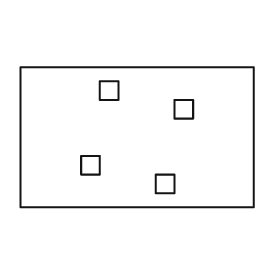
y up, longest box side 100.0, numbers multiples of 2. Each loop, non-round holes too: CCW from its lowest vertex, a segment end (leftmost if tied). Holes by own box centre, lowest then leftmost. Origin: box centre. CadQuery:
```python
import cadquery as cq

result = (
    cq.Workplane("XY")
    .moveTo(-50.0, -30.0)
    .lineTo(50.0, -30.0)
    .lineTo(50.0, 30.0)
    .lineTo(-50.0, 30.0)
    .close()
    .moveTo(8.0, -24.0)
    .lineTo(16.0, -24.0)
    .lineTo(16.0, -16.0)
    .lineTo(8.0, -16.0)
    .close()
    .moveTo(-24.0, -16.0)
    .lineTo(-16.0, -16.0)
    .lineTo(-16.0, -8.0)
    .lineTo(-24.0, -8.0)
    .close()
    .moveTo(16.0, 8.0)
    .lineTo(24.0, 8.0)
    .lineTo(24.0, 16.0)
    .lineTo(16.0, 16.0)
    .close()
    .moveTo(-16.0, 16.0)
    .lineTo(-8.0, 16.0)
    .lineTo(-8.0, 24.0)
    .lineTo(-16.0, 24.0)
    .close()
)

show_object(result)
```